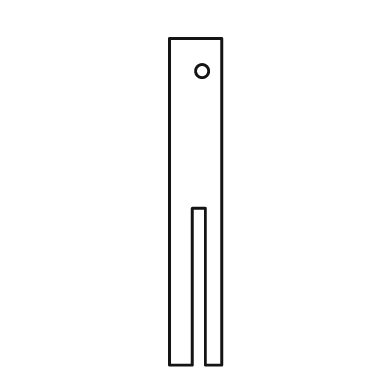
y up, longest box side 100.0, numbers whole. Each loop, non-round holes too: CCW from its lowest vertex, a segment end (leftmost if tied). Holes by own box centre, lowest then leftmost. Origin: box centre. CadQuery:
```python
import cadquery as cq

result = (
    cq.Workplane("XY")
    .moveTo(-8.0, -50.0)
    .lineTo(-1.0, -50.0)
    .lineTo(-1.0, -2.0)
    .lineTo(3.0, -2.0)
    .lineTo(3.0, -50.0)
    .lineTo(8.0, -50.0)
    .lineTo(8.0, 50.0)
    .lineTo(-8.0, 50.0)
    .close()
    .moveTo(2.0, 40.0)
    .circle(2.0)
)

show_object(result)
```